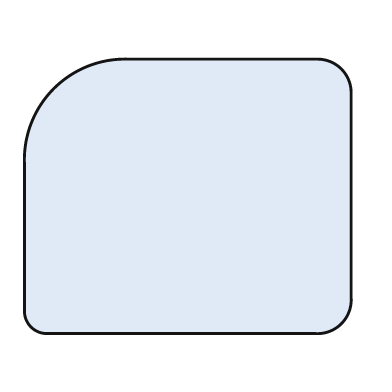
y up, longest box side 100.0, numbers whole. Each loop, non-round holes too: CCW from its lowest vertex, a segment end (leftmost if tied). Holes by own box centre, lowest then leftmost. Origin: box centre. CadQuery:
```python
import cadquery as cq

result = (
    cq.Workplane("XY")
    .moveTo(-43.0, -42.0)
    .lineTo(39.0, -42.0)
    .threePointArc((47.0, -39.0), (50.0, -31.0))
    .lineTo(50.0, 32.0)
    .threePointArc((47.0, 39.0), (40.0, 42.0))
    .lineTo(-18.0, 42.0)
    .threePointArc((-41.0, 33.0), (-50.0, 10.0))
    .lineTo(-50.0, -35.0)
    .threePointArc((-48.0, -40.0), (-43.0, -42.0))
    .close()
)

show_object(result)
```